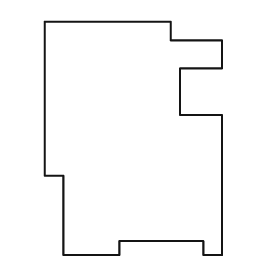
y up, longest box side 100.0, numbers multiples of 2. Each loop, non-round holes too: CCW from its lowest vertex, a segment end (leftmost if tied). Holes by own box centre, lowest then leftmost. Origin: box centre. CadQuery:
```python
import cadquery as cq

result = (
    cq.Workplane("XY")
    .moveTo(-30.0, -50.0)
    .lineTo(-6.0, -50.0)
    .lineTo(-6.0, -44.0)
    .lineTo(30.0, -44.0)
    .lineTo(30.0, -50.0)
    .lineTo(38.0, -50.0)
    .lineTo(38.0, 10.0)
    .lineTo(20.0, 10.0)
    .lineTo(20.0, 30.0)
    .lineTo(38.0, 30.0)
    .lineTo(38.0, 42.0)
    .lineTo(16.0, 42.0)
    .lineTo(16.0, 50.0)
    .lineTo(-38.0, 50.0)
    .lineTo(-38.0, -16.0)
    .lineTo(-30.0, -16.0)
    .close()
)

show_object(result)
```